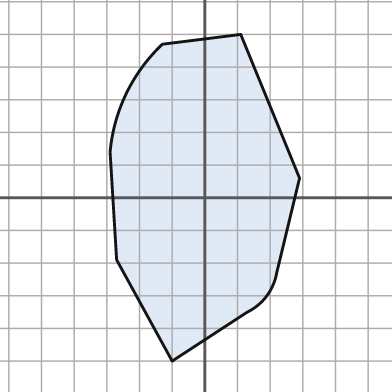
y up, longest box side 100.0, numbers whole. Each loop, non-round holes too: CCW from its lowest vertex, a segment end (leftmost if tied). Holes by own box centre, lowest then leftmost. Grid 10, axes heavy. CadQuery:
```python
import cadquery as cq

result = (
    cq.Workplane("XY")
    .moveTo(-10.0, -50.0)
    .lineTo(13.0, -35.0)
    .threePointArc((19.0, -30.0), (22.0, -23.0))
    .lineTo(29.0, 6.0)
    .lineTo(11.0, 50.0)
    .lineTo(-13.0, 47.0)
    .threePointArc((-24.0, 32.0), (-29.0, 14.0))
    .lineTo(-27.0, -19.0)
    .close()
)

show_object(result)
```